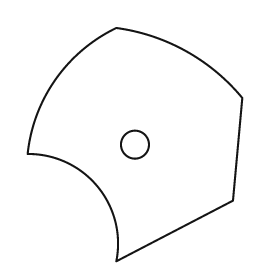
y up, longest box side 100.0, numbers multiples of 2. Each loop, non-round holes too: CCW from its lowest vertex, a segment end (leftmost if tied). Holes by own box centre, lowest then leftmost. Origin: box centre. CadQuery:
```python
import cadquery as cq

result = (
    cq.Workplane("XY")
    .moveTo(-8.0, -50.0)
    .lineTo(42.0, -24.0)
    .lineTo(46.0, 20.0)
    .threePointArc((22.0, 40.0), (-8.0, 50.0))
    .threePointArc((-34.0, 28.0), (-46.0, -4.0))
    .threePointArc((-16.0, -18.0), (-8.0, -50.0))
    .close()
    .moveTo(0.0, 0.0)
    .circle(6.0)
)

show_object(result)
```